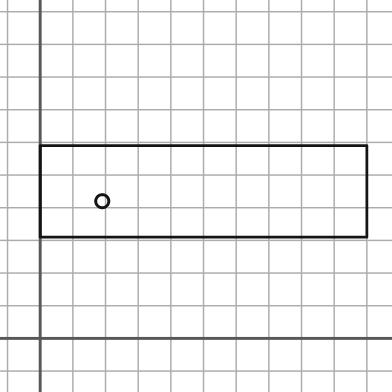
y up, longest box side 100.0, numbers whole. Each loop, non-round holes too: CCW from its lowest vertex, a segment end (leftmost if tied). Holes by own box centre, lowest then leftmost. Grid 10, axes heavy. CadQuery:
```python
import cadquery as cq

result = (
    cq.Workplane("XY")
    .moveTo(0.0, 31.0)
    .lineTo(100.0, 31.0)
    .lineTo(100.0, 59.0)
    .lineTo(0.0, 59.0)
    .close()
    .moveTo(19.0, 42.0)
    .circle(2.0)
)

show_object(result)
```